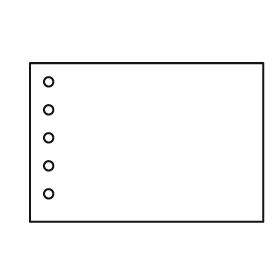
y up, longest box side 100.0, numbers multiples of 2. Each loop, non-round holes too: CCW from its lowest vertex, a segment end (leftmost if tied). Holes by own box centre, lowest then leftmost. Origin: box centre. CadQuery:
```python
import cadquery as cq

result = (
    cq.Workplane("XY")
    .moveTo(-50.0, -34.0)
    .lineTo(50.0, -34.0)
    .lineTo(50.0, 34.0)
    .lineTo(-50.0, 34.0)
    .close()
    .moveTo(-42.0, -22.0)
    .circle(2.0)
    .moveTo(-42.0, -10.0)
    .circle(2.0)
    .moveTo(-42.0, 2.0)
    .circle(2.0)
    .moveTo(-42.0, 14.0)
    .circle(2.0)
    .moveTo(-42.0, 26.0)
    .circle(2.0)
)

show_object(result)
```